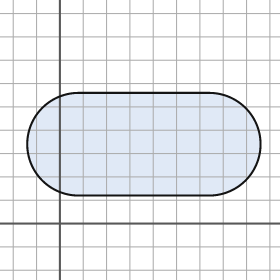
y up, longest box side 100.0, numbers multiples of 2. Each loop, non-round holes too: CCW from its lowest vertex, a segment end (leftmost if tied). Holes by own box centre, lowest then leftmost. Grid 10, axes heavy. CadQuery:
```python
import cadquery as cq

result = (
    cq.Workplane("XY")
    .moveTo(8.0, 12.0)
    .lineTo(64.0, 12.0)
    .threePointArc((86.0, 34.0), (64.0, 56.0))
    .lineTo(8.0, 56.0)
    .threePointArc((-14.0, 34.0), (8.0, 12.0))
    .close()
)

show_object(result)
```